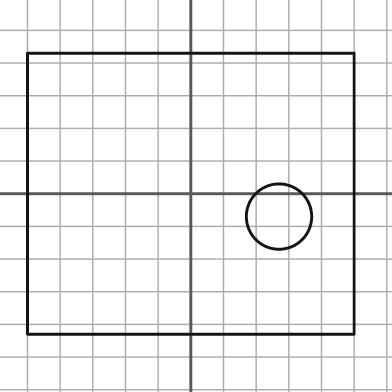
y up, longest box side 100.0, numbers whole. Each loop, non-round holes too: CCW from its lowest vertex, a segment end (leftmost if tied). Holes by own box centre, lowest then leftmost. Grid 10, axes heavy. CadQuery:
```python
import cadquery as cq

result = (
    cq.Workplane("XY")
    .moveTo(-50.0, -43.0)
    .lineTo(50.0, -43.0)
    .lineTo(50.0, 43.0)
    .lineTo(-50.0, 43.0)
    .close()
    .moveTo(27.0, -7.0)
    .circle(10.0)
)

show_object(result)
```